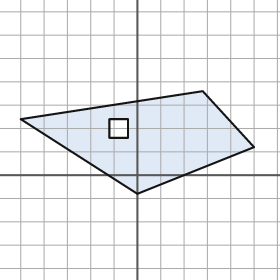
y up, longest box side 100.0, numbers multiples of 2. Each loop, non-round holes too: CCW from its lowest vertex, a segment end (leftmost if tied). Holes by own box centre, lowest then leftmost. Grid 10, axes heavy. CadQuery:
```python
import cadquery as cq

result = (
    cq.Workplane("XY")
    .moveTo(0.0, -8.0)
    .lineTo(50.0, 12.0)
    .lineTo(28.0, 36.0)
    .lineTo(-50.0, 24.0)
    .close()
    .moveTo(-12.0, 16.0)
    .lineTo(-4.0, 16.0)
    .lineTo(-4.0, 24.0)
    .lineTo(-12.0, 24.0)
    .close()
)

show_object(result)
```